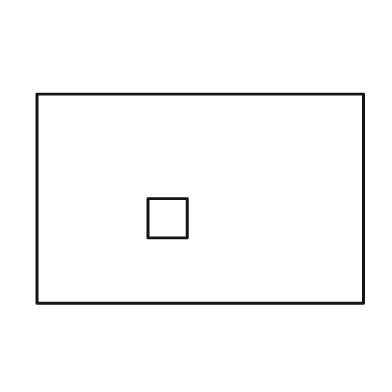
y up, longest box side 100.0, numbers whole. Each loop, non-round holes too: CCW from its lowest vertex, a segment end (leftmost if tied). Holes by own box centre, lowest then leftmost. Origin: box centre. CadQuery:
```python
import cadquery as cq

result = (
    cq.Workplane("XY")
    .moveTo(-50.0, -32.0)
    .lineTo(50.0, -32.0)
    .lineTo(50.0, 32.0)
    .lineTo(-50.0, 32.0)
    .close()
    .moveTo(-16.0, -12.0)
    .lineTo(-4.0, -12.0)
    .lineTo(-4.0, 0.0)
    .lineTo(-16.0, 0.0)
    .close()
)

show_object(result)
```